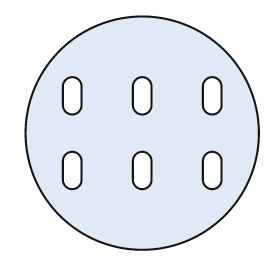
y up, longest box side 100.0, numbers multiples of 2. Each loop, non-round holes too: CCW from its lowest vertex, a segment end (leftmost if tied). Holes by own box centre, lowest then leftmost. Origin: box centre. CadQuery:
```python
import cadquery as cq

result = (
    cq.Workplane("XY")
    .moveTo(0.0, 0.0)
    .circle(50.0)
    .moveTo(-34.0, -20.0)
    .threePointArc((-30.0, -24.0), (-26.0, -20.0))
    .lineTo(-26.0, -12.0)
    .threePointArc((-30.0, -8.0), (-34.0, -12.0))
    .close()
    .moveTo(-4.0, -20.0)
    .threePointArc((0.0, -24.0), (4.0, -20.0))
    .lineTo(4.0, -12.0)
    .threePointArc((0.0, -8.0), (-4.0, -12.0))
    .close()
    .moveTo(26.0, -20.0)
    .threePointArc((30.0, -24.0), (34.0, -20.0))
    .lineTo(34.0, -12.0)
    .threePointArc((30.0, -8.0), (26.0, -12.0))
    .close()
    .moveTo(-34.0, 12.0)
    .threePointArc((-30.0, 8.0), (-26.0, 12.0))
    .lineTo(-26.0, 20.0)
    .threePointArc((-30.0, 24.0), (-34.0, 20.0))
    .close()
    .moveTo(-4.0, 12.0)
    .threePointArc((0.0, 8.0), (4.0, 12.0))
    .lineTo(4.0, 20.0)
    .threePointArc((0.0, 24.0), (-4.0, 20.0))
    .close()
    .moveTo(26.0, 12.0)
    .threePointArc((30.0, 8.0), (34.0, 12.0))
    .lineTo(34.0, 20.0)
    .threePointArc((30.0, 24.0), (26.0, 20.0))
    .close()
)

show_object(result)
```